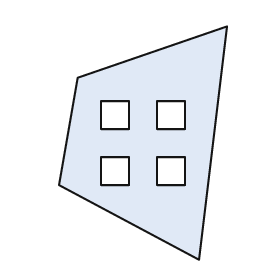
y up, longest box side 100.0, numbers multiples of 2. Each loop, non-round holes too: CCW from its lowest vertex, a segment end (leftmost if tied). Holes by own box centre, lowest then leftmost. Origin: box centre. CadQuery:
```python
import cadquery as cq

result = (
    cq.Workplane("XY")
    .moveTo(24.0, -50.0)
    .lineTo(36.0, 50.0)
    .lineTo(-28.0, 28.0)
    .lineTo(-36.0, -18.0)
    .close()
    .moveTo(-18.0, -18.0)
    .lineTo(-6.0, -18.0)
    .lineTo(-6.0, -6.0)
    .lineTo(-18.0, -6.0)
    .close()
    .moveTo(6.0, -18.0)
    .lineTo(18.0, -18.0)
    .lineTo(18.0, -6.0)
    .lineTo(6.0, -6.0)
    .close()
    .moveTo(-18.0, 6.0)
    .lineTo(-6.0, 6.0)
    .lineTo(-6.0, 18.0)
    .lineTo(-18.0, 18.0)
    .close()
    .moveTo(6.0, 6.0)
    .lineTo(18.0, 6.0)
    .lineTo(18.0, 18.0)
    .lineTo(6.0, 18.0)
    .close()
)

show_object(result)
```